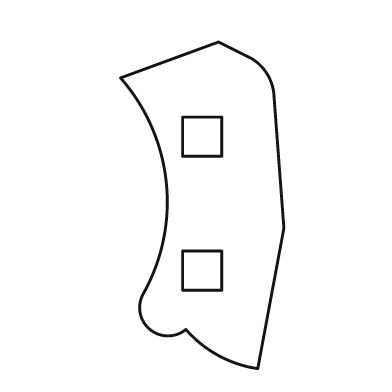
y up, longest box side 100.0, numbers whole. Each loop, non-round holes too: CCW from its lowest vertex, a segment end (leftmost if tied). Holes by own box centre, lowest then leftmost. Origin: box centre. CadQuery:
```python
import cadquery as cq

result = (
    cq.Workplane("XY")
    .moveTo(17.0, -50.0)
    .lineTo(25.0, -7.0)
    .lineTo(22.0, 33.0)
    .threePointArc((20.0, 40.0), (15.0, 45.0))
    .lineTo(5.0, 50.0)
    .lineTo(-25.0, 39.0)
    .threePointArc((-11.0, 7.0), (-18.0, -27.0))
    .threePointArc((-16.0, -38.0), (-5.0, -38.0))
    .threePointArc((5.0, -46.0), (17.0, -50.0))
    .close()
    .moveTo(-6.0, -26.0)
    .lineTo(6.0, -26.0)
    .lineTo(6.0, -14.0)
    .lineTo(-6.0, -14.0)
    .close()
    .moveTo(-6.0, 15.0)
    .lineTo(6.0, 15.0)
    .lineTo(6.0, 27.0)
    .lineTo(-6.0, 27.0)
    .close()
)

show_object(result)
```